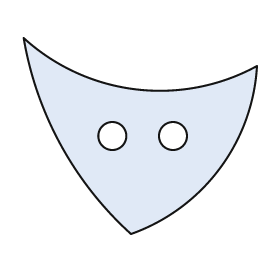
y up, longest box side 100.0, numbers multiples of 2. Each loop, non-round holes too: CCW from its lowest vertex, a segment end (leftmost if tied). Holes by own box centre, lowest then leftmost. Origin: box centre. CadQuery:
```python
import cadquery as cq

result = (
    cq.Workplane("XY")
    .moveTo(-4.0, -42.0)
    .threePointArc((34.0, -14.0), (50.0, 30.0))
    .threePointArc((-2.0, 20.0), (-50.0, 42.0))
    .threePointArc((-34.0, -4.0), (-4.0, -42.0))
    .close()
    .moveTo(-12.0, 0.0)
    .circle(6.0)
    .moveTo(14.0, 0.0)
    .circle(6.0)
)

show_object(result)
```